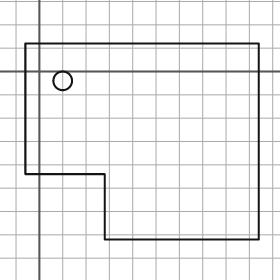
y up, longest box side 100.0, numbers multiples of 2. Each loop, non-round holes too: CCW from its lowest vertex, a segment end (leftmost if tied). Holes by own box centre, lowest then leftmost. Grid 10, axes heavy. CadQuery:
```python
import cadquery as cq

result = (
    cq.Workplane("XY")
    .moveTo(28.0, -72.0)
    .lineTo(94.0, -72.0)
    .lineTo(94.0, 12.0)
    .lineTo(-6.0, 12.0)
    .lineTo(-6.0, -44.0)
    .lineTo(28.0, -44.0)
    .close()
    .moveTo(10.0, -4.0)
    .circle(4.0)
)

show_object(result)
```